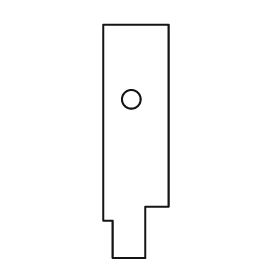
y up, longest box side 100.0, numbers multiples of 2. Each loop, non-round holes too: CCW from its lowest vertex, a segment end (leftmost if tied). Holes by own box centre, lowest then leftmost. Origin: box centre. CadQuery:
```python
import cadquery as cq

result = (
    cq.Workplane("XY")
    .moveTo(-10.0, -50.0)
    .lineTo(4.0, -50.0)
    .lineTo(4.0, -28.0)
    .lineTo(14.0, -28.0)
    .lineTo(14.0, 50.0)
    .lineTo(-14.0, 50.0)
    .lineTo(-14.0, -34.0)
    .lineTo(-10.0, -34.0)
    .close()
    .moveTo(-2.0, 18.0)
    .circle(4.0)
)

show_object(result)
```